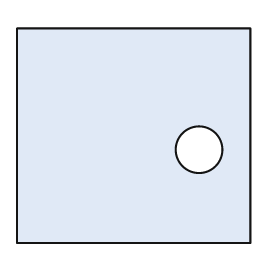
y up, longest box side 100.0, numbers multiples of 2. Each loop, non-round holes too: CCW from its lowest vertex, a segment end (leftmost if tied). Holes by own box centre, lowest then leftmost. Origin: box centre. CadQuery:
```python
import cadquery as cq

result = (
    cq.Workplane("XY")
    .moveTo(-50.0, -46.0)
    .lineTo(50.0, -46.0)
    .lineTo(50.0, 46.0)
    .lineTo(-50.0, 46.0)
    .close()
    .moveTo(28.0, -6.0)
    .circle(10.0)
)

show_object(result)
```